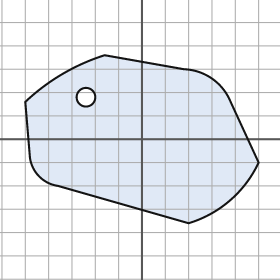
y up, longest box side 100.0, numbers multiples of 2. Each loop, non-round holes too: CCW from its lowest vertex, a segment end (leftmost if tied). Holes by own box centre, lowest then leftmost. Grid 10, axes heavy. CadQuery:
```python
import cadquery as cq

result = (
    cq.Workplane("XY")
    .moveTo(20.0, -36.0)
    .threePointArc((38.0, -26.0), (50.0, -10.0))
    .lineTo(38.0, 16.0)
    .threePointArc((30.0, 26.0), (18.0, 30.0))
    .lineTo(-16.0, 36.0)
    .threePointArc((-34.0, 28.0), (-50.0, 16.0))
    .lineTo(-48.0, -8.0)
    .threePointArc((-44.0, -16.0), (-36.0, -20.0))
    .close()
    .moveTo(-24.0, 18.0)
    .circle(4.0)
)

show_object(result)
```